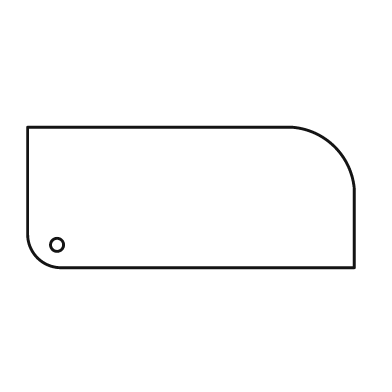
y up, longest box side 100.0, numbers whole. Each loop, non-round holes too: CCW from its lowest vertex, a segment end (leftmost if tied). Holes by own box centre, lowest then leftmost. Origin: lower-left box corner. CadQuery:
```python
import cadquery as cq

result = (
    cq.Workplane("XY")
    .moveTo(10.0, 0.0)
    .lineTo(100.0, 0.0)
    .lineTo(100.0, 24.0)
    .threePointArc((94.0, 37.0), (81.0, 43.0))
    .lineTo(0.0, 43.0)
    .lineTo(0.0, 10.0)
    .threePointArc((3.0, 3.0), (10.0, 0.0))
    .close()
    .moveTo(9.0, 7.0)
    .circle(2.0)
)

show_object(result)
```